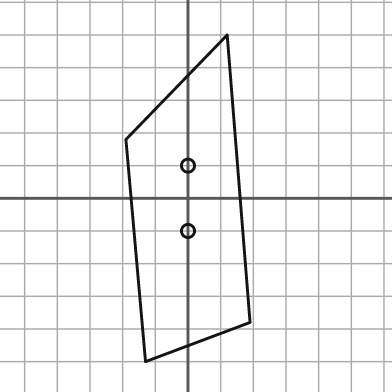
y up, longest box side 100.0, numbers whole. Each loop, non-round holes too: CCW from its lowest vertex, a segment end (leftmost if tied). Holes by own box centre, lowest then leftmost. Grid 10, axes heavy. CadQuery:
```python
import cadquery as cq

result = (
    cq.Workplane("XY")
    .moveTo(-13.0, -50.0)
    .lineTo(19.0, -38.0)
    .lineTo(12.0, 50.0)
    .lineTo(-19.0, 18.0)
    .close()
    .moveTo(0.0, -10.0)
    .circle(2.0)
    .moveTo(0.0, 10.0)
    .circle(2.0)
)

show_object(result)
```